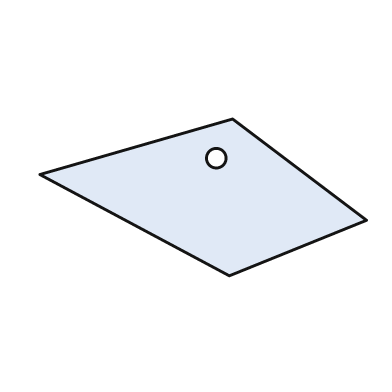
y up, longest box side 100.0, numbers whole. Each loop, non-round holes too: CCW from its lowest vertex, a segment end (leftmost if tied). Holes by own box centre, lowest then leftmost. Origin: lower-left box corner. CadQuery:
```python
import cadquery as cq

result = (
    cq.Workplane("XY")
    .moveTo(58.0, 0.0)
    .lineTo(100.0, 17.0)
    .lineTo(59.0, 48.0)
    .lineTo(0.0, 31.0)
    .close()
    .moveTo(54.0, 36.0)
    .circle(3.0)
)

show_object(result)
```